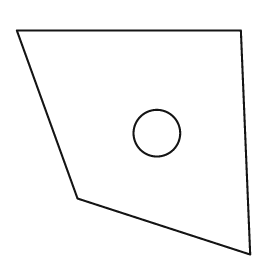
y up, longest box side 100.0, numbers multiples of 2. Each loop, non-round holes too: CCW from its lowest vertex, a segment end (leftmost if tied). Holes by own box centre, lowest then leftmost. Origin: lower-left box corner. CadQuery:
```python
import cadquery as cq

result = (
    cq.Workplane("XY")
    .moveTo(100.0, 0.0)
    .lineTo(96.0, 96.0)
    .lineTo(0.0, 96.0)
    .lineTo(26.0, 24.0)
    .close()
    .moveTo(60.0, 52.0)
    .circle(10.0)
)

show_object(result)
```